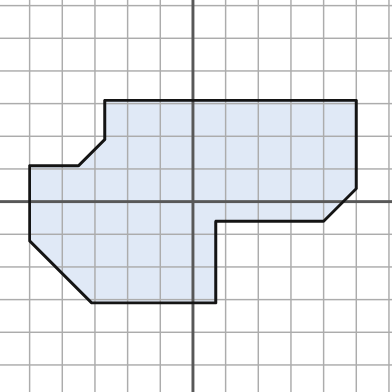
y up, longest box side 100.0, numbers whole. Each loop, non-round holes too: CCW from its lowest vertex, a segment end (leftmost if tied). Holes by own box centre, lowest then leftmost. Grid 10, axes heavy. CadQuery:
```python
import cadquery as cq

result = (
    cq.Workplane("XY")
    .moveTo(-31.0, -31.0)
    .lineTo(7.0, -31.0)
    .lineTo(7.0, -6.0)
    .lineTo(40.0, -6.0)
    .lineTo(50.0, 4.0)
    .lineTo(50.0, 31.0)
    .lineTo(-27.0, 31.0)
    .lineTo(-27.0, 19.0)
    .lineTo(-35.0, 11.0)
    .lineTo(-50.0, 11.0)
    .lineTo(-50.0, -12.0)
    .close()
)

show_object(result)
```